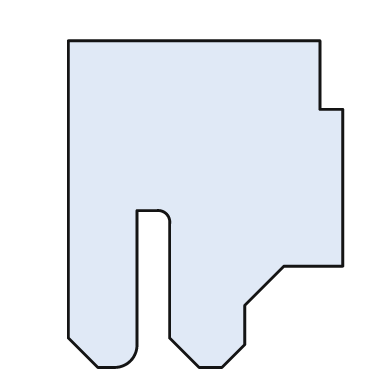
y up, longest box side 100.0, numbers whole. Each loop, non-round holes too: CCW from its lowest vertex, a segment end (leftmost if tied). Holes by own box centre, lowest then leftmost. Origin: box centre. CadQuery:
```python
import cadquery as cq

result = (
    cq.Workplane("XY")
    .moveTo(-33.0, -50.0)
    .lineTo(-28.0, -50.0)
    .threePointArc((-23.0, -48.0), (-21.0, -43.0))
    .lineTo(-21.0, -2.0)
    .lineTo(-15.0, -2.0)
    .threePointArc((-12.0, -3.0), (-11.0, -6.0))
    .lineTo(-11.0, -41.0)
    .lineTo(-2.0, -50.0)
    .lineTo(5.0, -50.0)
    .lineTo(12.0, -43.0)
    .lineTo(12.0, -31.0)
    .lineTo(24.0, -19.0)
    .lineTo(42.0, -19.0)
    .lineTo(42.0, 29.0)
    .lineTo(35.0, 29.0)
    .lineTo(35.0, 50.0)
    .lineTo(-42.0, 50.0)
    .lineTo(-42.0, -41.0)
    .close()
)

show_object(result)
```